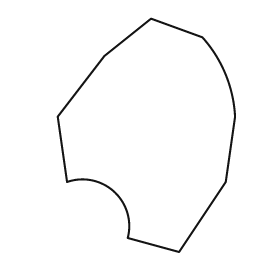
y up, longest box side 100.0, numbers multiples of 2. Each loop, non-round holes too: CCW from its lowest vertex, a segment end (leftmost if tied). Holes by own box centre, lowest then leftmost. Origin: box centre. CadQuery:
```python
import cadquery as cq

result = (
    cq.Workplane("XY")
    .moveTo(14.0, -50.0)
    .lineTo(34.0, -20.0)
    .lineTo(38.0, 8.0)
    .threePointArc((34.0, 26.0), (24.0, 42.0))
    .lineTo(2.0, 50.0)
    .lineTo(-18.0, 34.0)
    .lineTo(-38.0, 8.0)
    .lineTo(-34.0, -20.0)
    .threePointArc((-14.0, -24.0), (-8.0, -44.0))
    .close()
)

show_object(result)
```